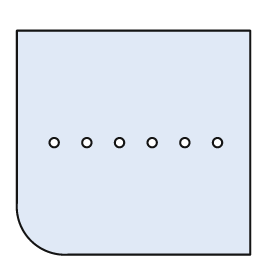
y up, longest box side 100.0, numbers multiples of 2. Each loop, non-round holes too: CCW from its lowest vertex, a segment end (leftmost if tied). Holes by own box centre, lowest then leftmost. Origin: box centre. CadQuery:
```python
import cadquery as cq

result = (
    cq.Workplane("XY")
    .moveTo(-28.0, -48.0)
    .lineTo(50.0, -48.0)
    .lineTo(50.0, 48.0)
    .lineTo(-50.0, 48.0)
    .lineTo(-50.0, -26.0)
    .threePointArc((-44.0, -42.0), (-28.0, -48.0))
    .close()
    .moveTo(-34.0, 0.0)
    .circle(2.0)
    .moveTo(-20.0, 0.0)
    .circle(2.0)
    .moveTo(-6.0, 0.0)
    .circle(2.0)
    .moveTo(8.0, 0.0)
    .circle(2.0)
    .moveTo(22.0, 0.0)
    .circle(2.0)
    .moveTo(36.0, 0.0)
    .circle(2.0)
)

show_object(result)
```